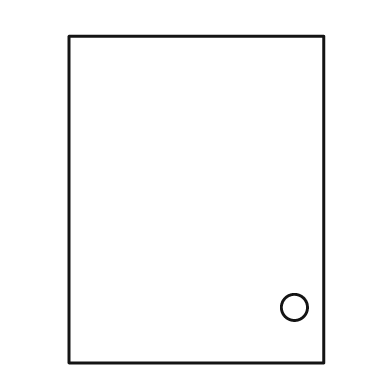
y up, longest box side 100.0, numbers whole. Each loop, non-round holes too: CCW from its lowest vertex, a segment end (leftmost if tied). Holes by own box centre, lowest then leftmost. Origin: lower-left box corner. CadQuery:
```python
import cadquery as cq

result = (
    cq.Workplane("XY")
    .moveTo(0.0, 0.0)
    .lineTo(78.0, 0.0)
    .lineTo(78.0, 100.0)
    .lineTo(0.0, 100.0)
    .close()
    .moveTo(69.0, 17.0)
    .circle(4.0)
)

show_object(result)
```